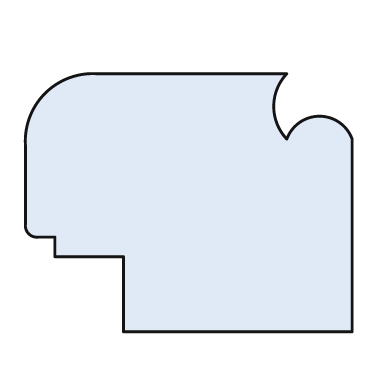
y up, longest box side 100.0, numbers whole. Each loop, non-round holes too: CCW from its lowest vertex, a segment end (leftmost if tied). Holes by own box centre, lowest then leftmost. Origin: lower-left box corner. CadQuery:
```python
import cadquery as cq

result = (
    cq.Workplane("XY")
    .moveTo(30.0, 0.0)
    .lineTo(100.0, 0.0)
    .lineTo(100.0, 59.0)
    .threePointArc((90.0, 66.0), (80.0, 59.0))
    .threePointArc((76.0, 69.0), (80.0, 79.0))
    .lineTo(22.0, 79.0)
    .threePointArc((6.0, 73.0), (0.0, 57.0))
    .lineTo(0.0, 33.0)
    .threePointArc((1.0, 30.0), (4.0, 29.0))
    .lineTo(9.0, 29.0)
    .lineTo(9.0, 23.0)
    .lineTo(30.0, 23.0)
    .close()
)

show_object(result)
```